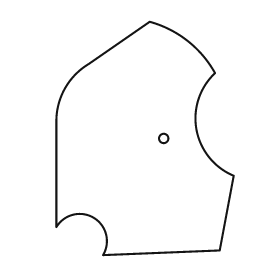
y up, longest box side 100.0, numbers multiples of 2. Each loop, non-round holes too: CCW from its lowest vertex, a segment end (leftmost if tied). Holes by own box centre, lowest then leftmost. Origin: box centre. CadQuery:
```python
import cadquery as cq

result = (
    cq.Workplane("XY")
    .moveTo(-18.0, -50.0)
    .lineTo(32.0, -48.0)
    .lineTo(38.0, -16.0)
    .threePointArc((22.0, 4.0), (30.0, 28.0))
    .threePointArc((18.0, 42.0), (2.0, 50.0))
    .lineTo(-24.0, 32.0)
    .threePointArc((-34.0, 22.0), (-38.0, 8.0))
    .lineTo(-38.0, -38.0)
    .threePointArc((-22.0, -34.0), (-18.0, -50.0))
    .close()
    .moveTo(8.0, 0.0)
    .circle(2.0)
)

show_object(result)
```